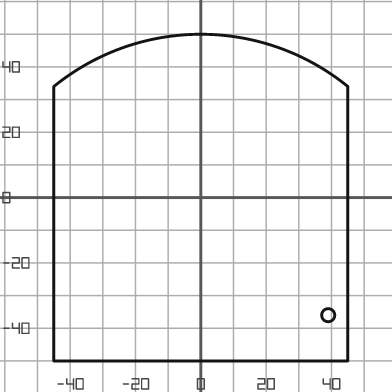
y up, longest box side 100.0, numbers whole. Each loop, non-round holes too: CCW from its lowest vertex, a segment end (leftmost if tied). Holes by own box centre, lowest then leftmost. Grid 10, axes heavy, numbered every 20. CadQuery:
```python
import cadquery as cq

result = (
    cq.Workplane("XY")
    .moveTo(-45.0, -50.0)
    .lineTo(45.0, -50.0)
    .lineTo(45.0, 34.0)
    .threePointArc((0.0, 50.0), (-45.0, 34.0))
    .close()
    .moveTo(39.0, -36.0)
    .circle(2.0)
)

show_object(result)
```